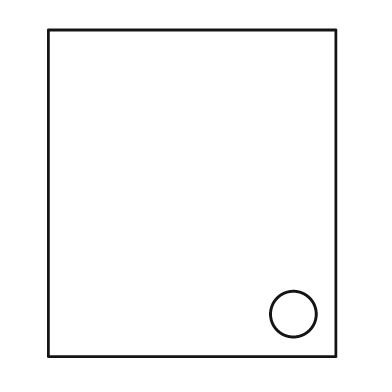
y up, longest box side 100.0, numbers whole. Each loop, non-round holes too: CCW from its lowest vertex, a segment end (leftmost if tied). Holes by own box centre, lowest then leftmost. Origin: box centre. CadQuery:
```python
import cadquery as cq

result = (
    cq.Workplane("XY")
    .moveTo(-44.0, -50.0)
    .lineTo(44.0, -50.0)
    .lineTo(44.0, 50.0)
    .lineTo(-44.0, 50.0)
    .close()
    .moveTo(31.0, -37.0)
    .circle(7.0)
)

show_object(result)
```